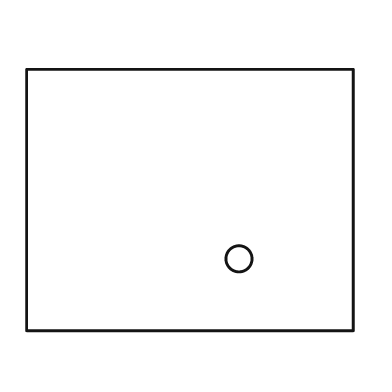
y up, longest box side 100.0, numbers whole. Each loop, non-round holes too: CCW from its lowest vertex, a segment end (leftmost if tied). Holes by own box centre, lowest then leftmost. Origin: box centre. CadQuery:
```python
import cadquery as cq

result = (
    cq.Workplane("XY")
    .moveTo(-50.0, -40.0)
    .lineTo(50.0, -40.0)
    .lineTo(50.0, 40.0)
    .lineTo(-50.0, 40.0)
    .close()
    .moveTo(15.0, -18.0)
    .circle(4.0)
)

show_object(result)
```